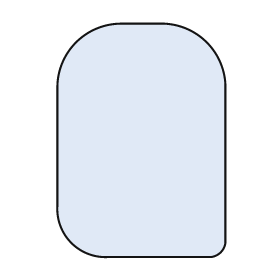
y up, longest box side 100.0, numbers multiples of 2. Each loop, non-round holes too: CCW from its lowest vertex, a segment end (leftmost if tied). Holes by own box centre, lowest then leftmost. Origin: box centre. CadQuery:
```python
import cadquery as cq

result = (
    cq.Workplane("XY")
    .moveTo(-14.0, -50.0)
    .lineTo(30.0, -50.0)
    .threePointArc((34.0, -48.0), (36.0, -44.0))
    .lineTo(36.0, 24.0)
    .threePointArc((28.0, 42.0), (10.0, 50.0))
    .lineTo(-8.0, 50.0)
    .threePointArc((-28.0, 42.0), (-36.0, 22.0))
    .lineTo(-36.0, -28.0)
    .threePointArc((-30.0, -44.0), (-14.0, -50.0))
    .close()
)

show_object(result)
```